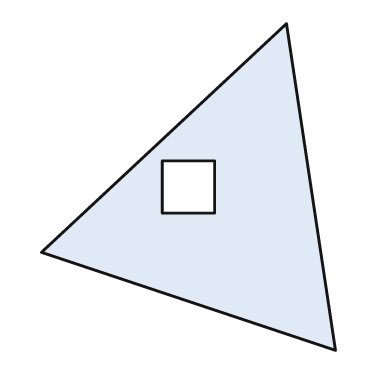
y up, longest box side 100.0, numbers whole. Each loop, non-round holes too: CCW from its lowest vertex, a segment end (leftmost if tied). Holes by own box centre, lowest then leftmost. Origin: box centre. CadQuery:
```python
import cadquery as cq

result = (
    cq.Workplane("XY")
    .moveTo(45.0, -50.0)
    .lineTo(30.0, 50.0)
    .lineTo(-45.0, -20.0)
    .close()
    .moveTo(-8.0, -8.0)
    .lineTo(8.0, -8.0)
    .lineTo(8.0, 8.0)
    .lineTo(-8.0, 8.0)
    .close()
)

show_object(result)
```